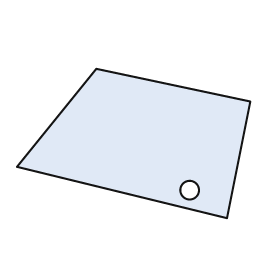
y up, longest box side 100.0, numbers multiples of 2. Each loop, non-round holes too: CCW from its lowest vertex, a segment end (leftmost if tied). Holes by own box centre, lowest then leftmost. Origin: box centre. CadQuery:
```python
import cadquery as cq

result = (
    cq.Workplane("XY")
    .moveTo(40.0, -32.0)
    .lineTo(50.0, 18.0)
    .lineTo(-16.0, 32.0)
    .lineTo(-50.0, -10.0)
    .close()
    .moveTo(24.0, -20.0)
    .circle(4.0)
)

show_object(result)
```